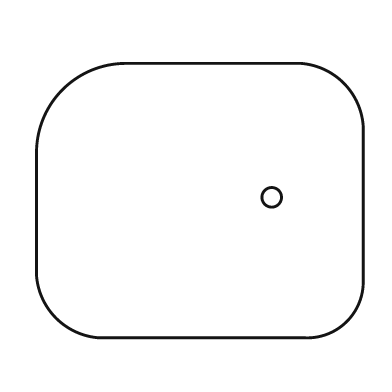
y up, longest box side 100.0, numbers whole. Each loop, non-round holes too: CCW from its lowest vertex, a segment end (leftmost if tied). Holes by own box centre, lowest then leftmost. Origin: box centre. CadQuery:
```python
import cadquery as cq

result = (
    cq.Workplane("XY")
    .moveTo(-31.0, -42.0)
    .lineTo(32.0, -42.0)
    .threePointArc((45.0, -37.0), (50.0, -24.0))
    .lineTo(50.0, 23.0)
    .threePointArc((44.0, 36.0), (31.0, 42.0))
    .lineTo(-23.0, 42.0)
    .threePointArc((-42.0, 34.0), (-50.0, 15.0))
    .lineTo(-50.0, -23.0)
    .threePointArc((-44.0, -36.0), (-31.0, -42.0))
    .close()
    .moveTo(22.0, 1.0)
    .circle(3.0)
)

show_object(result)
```